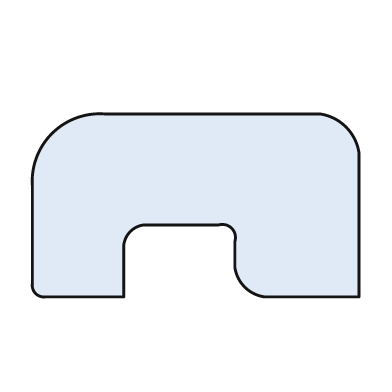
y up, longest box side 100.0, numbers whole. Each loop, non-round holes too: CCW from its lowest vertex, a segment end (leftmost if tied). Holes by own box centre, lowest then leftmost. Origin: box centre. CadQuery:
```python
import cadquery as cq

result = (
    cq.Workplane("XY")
    .moveTo(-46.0, -28.0)
    .lineTo(-22.0, -28.0)
    .lineTo(-22.0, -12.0)
    .threePointArc((-20.0, -8.0), (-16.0, -6.0))
    .lineTo(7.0, -6.0)
    .threePointArc((11.0, -7.0), (12.0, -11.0))
    .lineTo(12.0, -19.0)
    .threePointArc((15.0, -25.0), (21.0, -28.0))
    .lineTo(50.0, -28.0)
    .lineTo(50.0, 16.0)
    .threePointArc((46.0, 24.0), (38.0, 28.0))
    .lineTo(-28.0, 28.0)
    .threePointArc((-44.0, 22.0), (-50.0, 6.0))
    .lineTo(-50.0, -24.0)
    .threePointArc((-49.0, -27.0), (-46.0, -28.0))
    .close()
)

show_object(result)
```